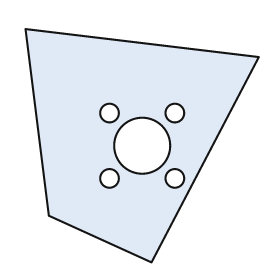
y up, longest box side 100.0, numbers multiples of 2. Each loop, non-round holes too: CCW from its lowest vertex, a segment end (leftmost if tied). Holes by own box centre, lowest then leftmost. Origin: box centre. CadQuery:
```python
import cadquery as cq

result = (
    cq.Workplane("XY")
    .moveTo(4.0, -50.0)
    .lineTo(50.0, 38.0)
    .lineTo(-50.0, 50.0)
    .lineTo(-40.0, -30.0)
    .close()
    .moveTo(-14.0, -14.0)
    .circle(4.0)
    .moveTo(14.0, -14.0)
    .circle(4.0)
    .moveTo(0.0, 0.0)
    .circle(12.0)
    .moveTo(-14.0, 14.0)
    .circle(4.0)
    .moveTo(14.0, 14.0)
    .circle(4.0)
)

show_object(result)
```